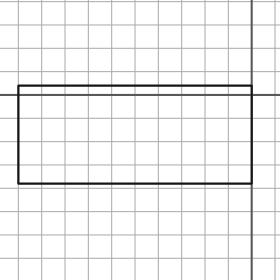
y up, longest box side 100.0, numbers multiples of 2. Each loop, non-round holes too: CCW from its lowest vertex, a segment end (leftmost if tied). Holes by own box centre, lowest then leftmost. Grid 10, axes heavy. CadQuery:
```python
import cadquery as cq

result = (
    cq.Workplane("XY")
    .moveTo(-100.0, -38.0)
    .lineTo(0.0, -38.0)
    .lineTo(0.0, 4.0)
    .lineTo(-100.0, 4.0)
    .close()
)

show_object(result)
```